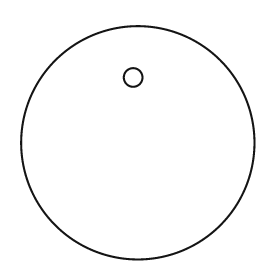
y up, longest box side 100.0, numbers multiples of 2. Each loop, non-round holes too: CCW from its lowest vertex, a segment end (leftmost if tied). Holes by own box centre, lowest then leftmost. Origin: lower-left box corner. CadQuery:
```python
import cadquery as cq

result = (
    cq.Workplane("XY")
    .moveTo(50.0, 50.0)
    .circle(50.0)
    .moveTo(48.0, 78.0)
    .circle(4.0)
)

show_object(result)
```